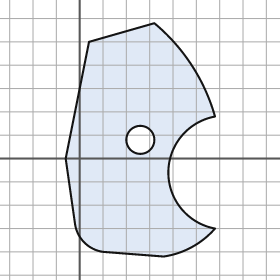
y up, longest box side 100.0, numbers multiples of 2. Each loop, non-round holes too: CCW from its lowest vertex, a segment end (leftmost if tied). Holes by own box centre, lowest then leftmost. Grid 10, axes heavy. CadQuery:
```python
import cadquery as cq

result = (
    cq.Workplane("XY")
    .moveTo(36.0, -42.0)
    .threePointArc((48.0, -38.0), (58.0, -30.0))
    .threePointArc((38.0, -6.0), (58.0, 18.0))
    .threePointArc((48.0, 40.0), (32.0, 58.0))
    .lineTo(4.0, 50.0)
    .lineTo(-6.0, 0.0)
    .lineTo(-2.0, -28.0)
    .threePointArc((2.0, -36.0), (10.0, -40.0))
    .close()
    .moveTo(26.0, 8.0)
    .circle(6.0)
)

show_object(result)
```